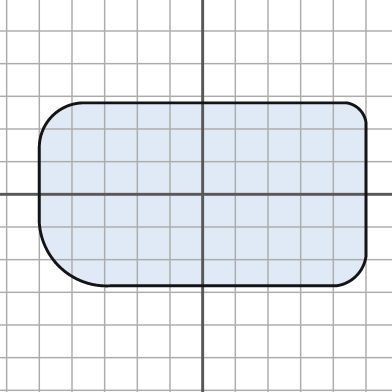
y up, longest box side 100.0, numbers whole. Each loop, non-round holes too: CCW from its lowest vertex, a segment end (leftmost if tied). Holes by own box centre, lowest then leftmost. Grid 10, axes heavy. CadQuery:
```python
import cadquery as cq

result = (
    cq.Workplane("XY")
    .moveTo(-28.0, -28.0)
    .lineTo(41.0, -28.0)
    .threePointArc((47.0, -25.0), (50.0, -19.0))
    .lineTo(50.0, 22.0)
    .threePointArc((48.0, 26.0), (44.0, 28.0))
    .lineTo(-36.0, 28.0)
    .threePointArc((-46.0, 24.0), (-50.0, 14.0))
    .lineTo(-50.0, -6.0)
    .threePointArc((-44.0, -22.0), (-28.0, -28.0))
    .close()
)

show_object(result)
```